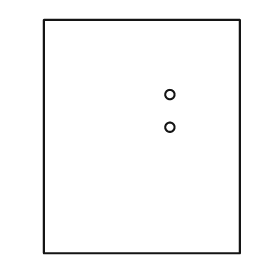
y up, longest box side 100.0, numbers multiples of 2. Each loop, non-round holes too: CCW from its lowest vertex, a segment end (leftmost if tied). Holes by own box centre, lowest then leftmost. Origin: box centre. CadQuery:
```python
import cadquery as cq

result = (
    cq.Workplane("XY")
    .moveTo(-42.0, -50.0)
    .lineTo(42.0, -50.0)
    .lineTo(42.0, 50.0)
    .lineTo(-42.0, 50.0)
    .close()
    .moveTo(12.0, 4.0)
    .circle(2.0)
    .moveTo(12.0, 18.0)
    .circle(2.0)
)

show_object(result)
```